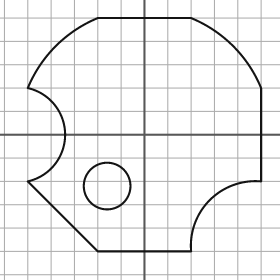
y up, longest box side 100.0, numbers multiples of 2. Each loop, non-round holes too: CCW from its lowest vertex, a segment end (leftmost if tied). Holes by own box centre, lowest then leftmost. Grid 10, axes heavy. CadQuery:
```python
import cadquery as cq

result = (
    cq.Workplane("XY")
    .moveTo(-20.0, -50.0)
    .lineTo(20.0, -50.0)
    .threePointArc((28.0, -28.0), (50.0, -20.0))
    .lineTo(50.0, 20.0)
    .threePointArc((38.0, 38.0), (20.0, 50.0))
    .lineTo(-20.0, 50.0)
    .threePointArc((-38.0, 38.0), (-50.0, 20.0))
    .threePointArc((-34.0, 0.0), (-50.0, -20.0))
    .close()
    .moveTo(-16.0, -22.0)
    .circle(10.0)
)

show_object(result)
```